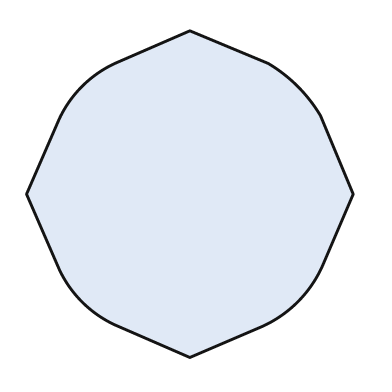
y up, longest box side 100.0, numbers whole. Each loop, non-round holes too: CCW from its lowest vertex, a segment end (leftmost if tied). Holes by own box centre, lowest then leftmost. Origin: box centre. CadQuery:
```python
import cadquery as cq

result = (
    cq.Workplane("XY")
    .moveTo(0.0, -50.0)
    .lineTo(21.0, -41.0)
    .threePointArc((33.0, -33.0), (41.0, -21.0))
    .lineTo(50.0, 0.0)
    .lineTo(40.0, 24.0)
    .threePointArc((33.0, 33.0), (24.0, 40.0))
    .lineTo(0.0, 50.0)
    .lineTo(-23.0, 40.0)
    .threePointArc((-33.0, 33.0), (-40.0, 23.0))
    .lineTo(-50.0, 0.0)
    .lineTo(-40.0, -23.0)
    .threePointArc((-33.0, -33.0), (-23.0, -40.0))
    .close()
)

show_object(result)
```